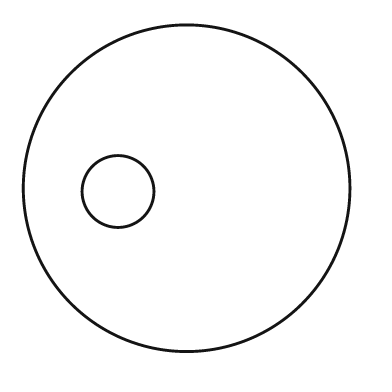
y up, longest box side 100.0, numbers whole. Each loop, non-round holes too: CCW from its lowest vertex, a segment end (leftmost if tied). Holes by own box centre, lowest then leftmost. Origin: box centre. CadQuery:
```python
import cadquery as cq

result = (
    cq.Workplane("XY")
    .moveTo(0.0, 0.0)
    .circle(50.0)
    .moveTo(-21.0, -1.0)
    .circle(11.0)
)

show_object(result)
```